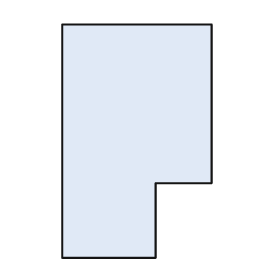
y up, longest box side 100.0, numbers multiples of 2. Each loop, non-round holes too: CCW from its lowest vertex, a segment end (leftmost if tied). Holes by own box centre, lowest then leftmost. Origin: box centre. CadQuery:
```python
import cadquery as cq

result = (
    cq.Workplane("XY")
    .moveTo(-32.0, -50.0)
    .lineTo(8.0, -50.0)
    .lineTo(8.0, -18.0)
    .lineTo(32.0, -18.0)
    .lineTo(32.0, 50.0)
    .lineTo(-32.0, 50.0)
    .close()
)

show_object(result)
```